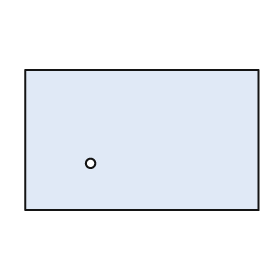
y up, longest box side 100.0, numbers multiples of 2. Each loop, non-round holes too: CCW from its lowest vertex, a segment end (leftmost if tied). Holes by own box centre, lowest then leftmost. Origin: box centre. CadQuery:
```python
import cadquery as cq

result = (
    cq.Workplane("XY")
    .moveTo(-50.0, -30.0)
    .lineTo(50.0, -30.0)
    .lineTo(50.0, 30.0)
    .lineTo(-50.0, 30.0)
    .close()
    .moveTo(-22.0, -10.0)
    .circle(2.0)
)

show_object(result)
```